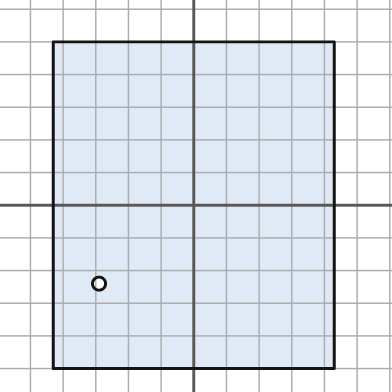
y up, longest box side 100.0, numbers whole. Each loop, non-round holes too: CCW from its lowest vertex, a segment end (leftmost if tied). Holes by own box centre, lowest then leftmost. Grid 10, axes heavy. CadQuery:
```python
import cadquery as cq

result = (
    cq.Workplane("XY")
    .moveTo(-43.0, -50.0)
    .lineTo(43.0, -50.0)
    .lineTo(43.0, 50.0)
    .lineTo(-43.0, 50.0)
    .close()
    .moveTo(-29.0, -24.0)
    .circle(2.0)
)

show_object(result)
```